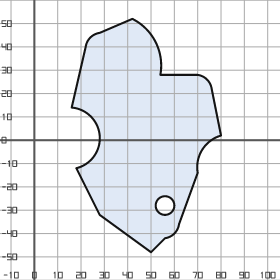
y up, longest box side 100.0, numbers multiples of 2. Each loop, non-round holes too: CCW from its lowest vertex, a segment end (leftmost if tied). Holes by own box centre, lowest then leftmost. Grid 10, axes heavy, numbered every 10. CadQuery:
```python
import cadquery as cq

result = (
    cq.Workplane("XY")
    .moveTo(50.0, -48.0)
    .lineTo(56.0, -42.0)
    .threePointArc((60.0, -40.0), (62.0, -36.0))
    .lineTo(70.0, -14.0)
    .threePointArc((72.0, -4.0), (80.0, 2.0))
    .lineTo(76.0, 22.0)
    .threePointArc((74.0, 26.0), (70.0, 28.0))
    .lineTo(54.0, 28.0)
    .threePointArc((52.0, 42.0), (42.0, 52.0))
    .lineTo(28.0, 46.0)
    .threePointArc((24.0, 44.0), (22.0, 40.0))
    .lineTo(16.0, 14.0)
    .threePointArc((28.0, 2.0), (18.0, -12.0))
    .lineTo(28.0, -32.0)
    .close()
    .moveTo(56.0, -28.0)
    .circle(4.0)
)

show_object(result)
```